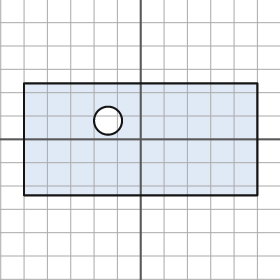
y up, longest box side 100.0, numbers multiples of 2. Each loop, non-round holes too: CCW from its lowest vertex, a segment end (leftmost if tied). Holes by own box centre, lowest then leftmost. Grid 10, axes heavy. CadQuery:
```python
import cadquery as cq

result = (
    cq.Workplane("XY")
    .moveTo(-50.0, -24.0)
    .lineTo(50.0, -24.0)
    .lineTo(50.0, 24.0)
    .lineTo(-50.0, 24.0)
    .close()
    .moveTo(-14.0, 8.0)
    .circle(6.0)
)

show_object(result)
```